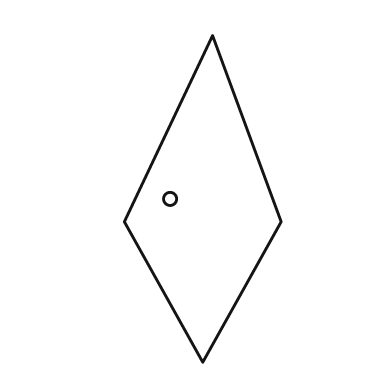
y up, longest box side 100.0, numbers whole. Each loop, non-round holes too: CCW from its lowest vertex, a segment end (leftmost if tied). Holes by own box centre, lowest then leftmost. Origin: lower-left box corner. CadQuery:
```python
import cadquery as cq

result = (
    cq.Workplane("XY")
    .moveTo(24.0, 0.0)
    .lineTo(48.0, 43.0)
    .lineTo(27.0, 100.0)
    .lineTo(0.0, 43.0)
    .close()
    .moveTo(14.0, 50.0)
    .circle(2.0)
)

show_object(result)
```